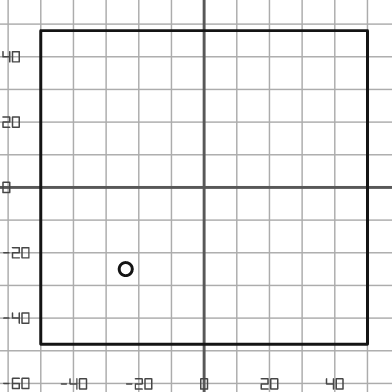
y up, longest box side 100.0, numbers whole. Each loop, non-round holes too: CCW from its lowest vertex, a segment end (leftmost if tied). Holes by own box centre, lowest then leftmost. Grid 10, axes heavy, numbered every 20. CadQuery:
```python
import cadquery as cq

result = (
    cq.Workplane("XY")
    .moveTo(-50.0, -48.0)
    .lineTo(50.0, -48.0)
    .lineTo(50.0, 48.0)
    .lineTo(-50.0, 48.0)
    .close()
    .moveTo(-24.0, -25.0)
    .circle(2.0)
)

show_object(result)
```